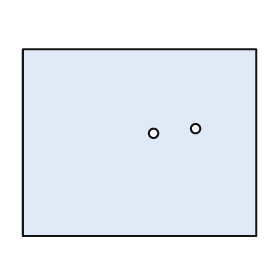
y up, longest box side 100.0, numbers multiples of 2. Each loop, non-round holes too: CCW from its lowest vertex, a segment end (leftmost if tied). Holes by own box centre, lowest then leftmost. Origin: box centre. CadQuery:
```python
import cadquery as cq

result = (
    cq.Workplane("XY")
    .moveTo(-50.0, -40.0)
    .lineTo(50.0, -40.0)
    .lineTo(50.0, 40.0)
    .lineTo(-50.0, 40.0)
    .close()
    .moveTo(6.0, 4.0)
    .circle(2.0)
    .moveTo(24.0, 6.0)
    .circle(2.0)
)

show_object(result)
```